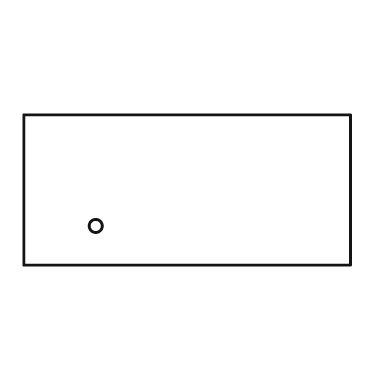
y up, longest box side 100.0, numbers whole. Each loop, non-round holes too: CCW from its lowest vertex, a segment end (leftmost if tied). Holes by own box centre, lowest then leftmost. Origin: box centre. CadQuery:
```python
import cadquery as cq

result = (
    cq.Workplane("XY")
    .moveTo(-50.0, -23.0)
    .lineTo(50.0, -23.0)
    .lineTo(50.0, 23.0)
    .lineTo(-50.0, 23.0)
    .close()
    .moveTo(-28.0, -11.0)
    .circle(2.0)
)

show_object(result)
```